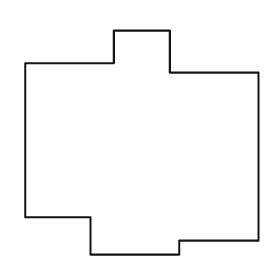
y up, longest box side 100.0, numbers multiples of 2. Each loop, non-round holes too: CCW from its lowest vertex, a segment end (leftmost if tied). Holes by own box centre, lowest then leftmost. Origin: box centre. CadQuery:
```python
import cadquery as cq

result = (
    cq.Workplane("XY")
    .moveTo(-22.0, -48.0)
    .lineTo(16.0, -48.0)
    .lineTo(16.0, -42.0)
    .lineTo(50.0, -42.0)
    .lineTo(50.0, 30.0)
    .lineTo(12.0, 30.0)
    .lineTo(12.0, 48.0)
    .lineTo(-12.0, 48.0)
    .lineTo(-12.0, 34.0)
    .lineTo(-50.0, 34.0)
    .lineTo(-50.0, -32.0)
    .lineTo(-22.0, -32.0)
    .close()
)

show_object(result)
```